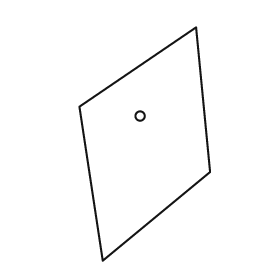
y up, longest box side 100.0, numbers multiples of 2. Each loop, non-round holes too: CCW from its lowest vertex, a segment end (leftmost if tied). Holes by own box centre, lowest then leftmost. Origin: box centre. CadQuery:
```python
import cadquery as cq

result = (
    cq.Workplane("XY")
    .moveTo(-18.0, -50.0)
    .lineTo(28.0, -12.0)
    .lineTo(22.0, 50.0)
    .lineTo(-28.0, 16.0)
    .close()
    .moveTo(-2.0, 12.0)
    .circle(2.0)
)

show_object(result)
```